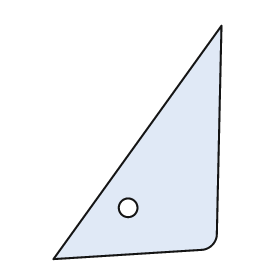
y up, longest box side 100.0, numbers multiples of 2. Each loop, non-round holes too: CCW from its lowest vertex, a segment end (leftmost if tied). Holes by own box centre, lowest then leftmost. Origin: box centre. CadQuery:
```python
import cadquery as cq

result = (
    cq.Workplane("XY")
    .moveTo(-36.0, -50.0)
    .lineTo(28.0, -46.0)
    .threePointArc((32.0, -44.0), (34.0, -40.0))
    .lineTo(36.0, 50.0)
    .close()
    .moveTo(-4.0, -28.0)
    .circle(4.0)
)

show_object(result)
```